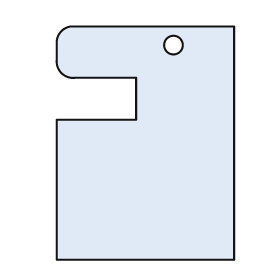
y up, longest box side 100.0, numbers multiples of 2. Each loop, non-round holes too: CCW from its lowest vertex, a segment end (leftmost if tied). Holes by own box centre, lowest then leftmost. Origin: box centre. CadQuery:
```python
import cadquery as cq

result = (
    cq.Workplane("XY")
    .moveTo(-38.0, -50.0)
    .lineTo(38.0, -50.0)
    .lineTo(38.0, 50.0)
    .lineTo(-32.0, 50.0)
    .threePointArc((-36.0, 48.0), (-38.0, 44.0))
    .lineTo(-38.0, 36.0)
    .threePointArc((-36.0, 30.0), (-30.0, 28.0))
    .lineTo(-4.0, 28.0)
    .lineTo(-4.0, 10.0)
    .lineTo(-38.0, 10.0)
    .close()
    .moveTo(12.0, 42.0)
    .circle(4.0)
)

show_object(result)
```